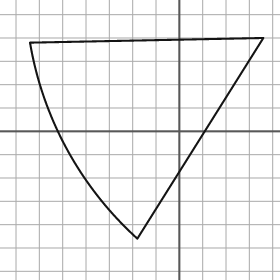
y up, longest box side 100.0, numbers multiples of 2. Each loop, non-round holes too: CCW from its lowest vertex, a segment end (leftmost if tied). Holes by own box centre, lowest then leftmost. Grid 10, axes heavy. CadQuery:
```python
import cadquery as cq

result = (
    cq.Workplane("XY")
    .moveTo(-18.0, -46.0)
    .lineTo(36.0, 40.0)
    .lineTo(-64.0, 38.0)
    .threePointArc((-48.0, -8.0), (-18.0, -46.0))
    .close()
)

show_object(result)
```